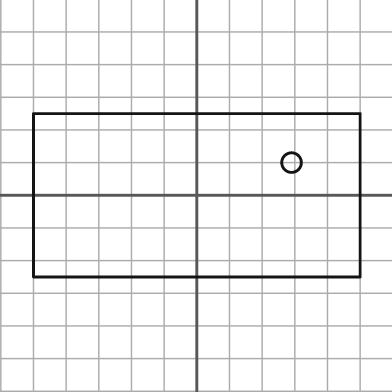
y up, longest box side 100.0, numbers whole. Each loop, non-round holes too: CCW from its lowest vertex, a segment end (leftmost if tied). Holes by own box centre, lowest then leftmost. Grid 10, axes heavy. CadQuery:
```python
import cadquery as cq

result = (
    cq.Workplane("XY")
    .moveTo(-50.0, -25.0)
    .lineTo(50.0, -25.0)
    .lineTo(50.0, 25.0)
    .lineTo(-50.0, 25.0)
    .close()
    .moveTo(29.0, 10.0)
    .circle(3.0)
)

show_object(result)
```